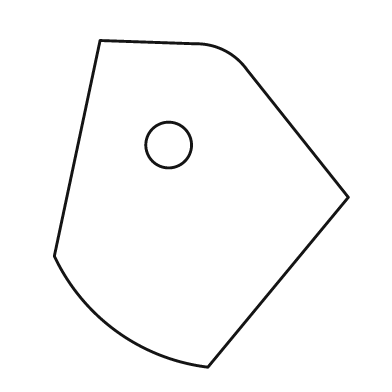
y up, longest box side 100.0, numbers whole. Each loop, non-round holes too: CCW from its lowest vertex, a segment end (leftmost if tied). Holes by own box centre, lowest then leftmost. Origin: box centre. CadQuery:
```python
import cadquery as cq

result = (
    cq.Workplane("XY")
    .moveTo(2.0, -50.0)
    .lineTo(45.0, 2.0)
    .lineTo(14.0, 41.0)
    .threePointArc((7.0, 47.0), (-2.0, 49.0))
    .lineTo(-31.0, 50.0)
    .lineTo(-45.0, -16.0)
    .threePointArc((-26.0, -39.0), (2.0, -50.0))
    .close()
    .moveTo(-10.0, 18.0)
    .circle(7.0)
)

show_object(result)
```